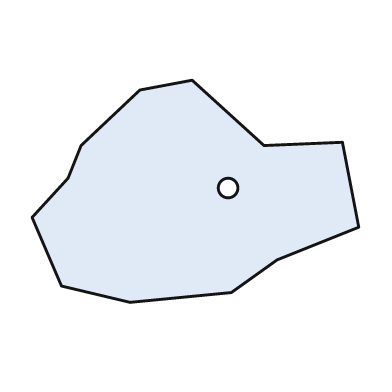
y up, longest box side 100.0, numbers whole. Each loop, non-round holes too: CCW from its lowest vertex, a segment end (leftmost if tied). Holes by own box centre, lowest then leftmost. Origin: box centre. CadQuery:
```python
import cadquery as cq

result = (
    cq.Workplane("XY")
    .moveTo(-20.0, -34.0)
    .lineTo(11.0, -31.0)
    .lineTo(25.0, -21.0)
    .lineTo(50.0, -11.0)
    .lineTo(45.0, 15.0)
    .lineTo(21.0, 14.0)
    .lineTo(-1.0, 34.0)
    .lineTo(-17.0, 31.0)
    .lineTo(-35.0, 14.0)
    .lineTo(-39.0, 4.0)
    .lineTo(-50.0, -8.0)
    .lineTo(-41.0, -29.0)
    .close()
    .moveTo(10.0, 1.0)
    .circle(3.0)
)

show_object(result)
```